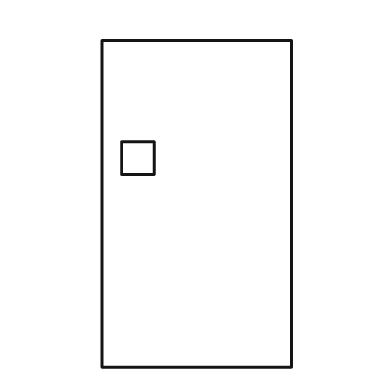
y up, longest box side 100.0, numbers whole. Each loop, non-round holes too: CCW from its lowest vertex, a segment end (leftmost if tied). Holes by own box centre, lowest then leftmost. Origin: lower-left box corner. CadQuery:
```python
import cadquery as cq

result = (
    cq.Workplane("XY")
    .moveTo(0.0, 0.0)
    .lineTo(58.0, 0.0)
    .lineTo(58.0, 100.0)
    .lineTo(0.0, 100.0)
    .close()
    .moveTo(6.0, 59.0)
    .lineTo(16.0, 59.0)
    .lineTo(16.0, 69.0)
    .lineTo(6.0, 69.0)
    .close()
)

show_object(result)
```